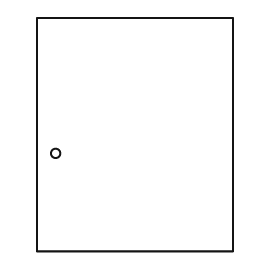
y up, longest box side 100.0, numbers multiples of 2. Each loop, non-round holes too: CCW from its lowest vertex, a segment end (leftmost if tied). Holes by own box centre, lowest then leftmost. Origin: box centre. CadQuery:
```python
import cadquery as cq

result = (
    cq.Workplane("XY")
    .moveTo(-42.0, -50.0)
    .lineTo(42.0, -50.0)
    .lineTo(42.0, 50.0)
    .lineTo(-42.0, 50.0)
    .close()
    .moveTo(-34.0, -8.0)
    .circle(2.0)
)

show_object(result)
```